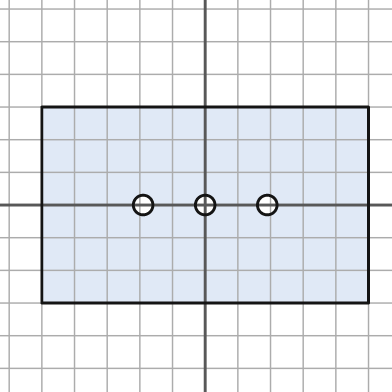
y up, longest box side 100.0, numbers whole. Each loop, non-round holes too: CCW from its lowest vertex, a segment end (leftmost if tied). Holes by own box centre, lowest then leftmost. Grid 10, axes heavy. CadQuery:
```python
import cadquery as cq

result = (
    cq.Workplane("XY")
    .moveTo(-50.0, -30.0)
    .lineTo(50.0, -30.0)
    .lineTo(50.0, 30.0)
    .lineTo(-50.0, 30.0)
    .close()
    .moveTo(-19.0, 0.0)
    .circle(3.0)
    .moveTo(0.0, 0.0)
    .circle(3.0)
    .moveTo(19.0, 0.0)
    .circle(3.0)
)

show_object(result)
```